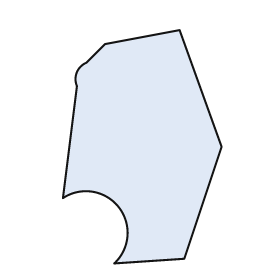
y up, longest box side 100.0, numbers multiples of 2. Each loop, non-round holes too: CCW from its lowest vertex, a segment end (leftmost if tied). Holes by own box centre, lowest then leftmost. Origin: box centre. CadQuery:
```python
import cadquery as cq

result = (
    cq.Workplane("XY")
    .moveTo(-12.0, -50.0)
    .lineTo(18.0, -48.0)
    .lineTo(34.0, 0.0)
    .lineTo(16.0, 50.0)
    .lineTo(-16.0, 44.0)
    .lineTo(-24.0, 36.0)
    .threePointArc((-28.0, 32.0), (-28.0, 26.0))
    .lineTo(-34.0, -22.0)
    .threePointArc((-10.0, -26.0), (-12.0, -50.0))
    .close()
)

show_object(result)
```